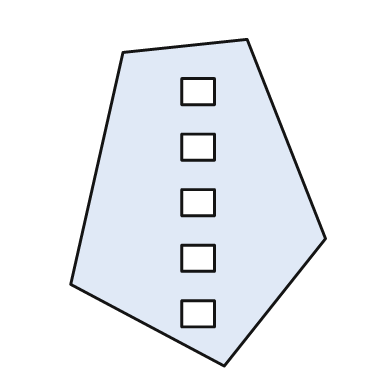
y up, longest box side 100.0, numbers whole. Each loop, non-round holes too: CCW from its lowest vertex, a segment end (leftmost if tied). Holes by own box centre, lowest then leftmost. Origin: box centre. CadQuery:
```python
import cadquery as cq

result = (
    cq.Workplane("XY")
    .moveTo(8.0, -50.0)
    .lineTo(39.0, -11.0)
    .lineTo(15.0, 50.0)
    .lineTo(-23.0, 46.0)
    .lineTo(-39.0, -25.0)
    .close()
    .moveTo(-5.0, -38.0)
    .lineTo(5.0, -38.0)
    .lineTo(5.0, -30.0)
    .lineTo(-5.0, -30.0)
    .close()
    .moveTo(-5.0, -21.0)
    .lineTo(5.0, -21.0)
    .lineTo(5.0, -13.0)
    .lineTo(-5.0, -13.0)
    .close()
    .moveTo(-5.0, -4.0)
    .lineTo(5.0, -4.0)
    .lineTo(5.0, 4.0)
    .lineTo(-5.0, 4.0)
    .close()
    .moveTo(-5.0, 13.0)
    .lineTo(5.0, 13.0)
    .lineTo(5.0, 21.0)
    .lineTo(-5.0, 21.0)
    .close()
    .moveTo(-5.0, 30.0)
    .lineTo(5.0, 30.0)
    .lineTo(5.0, 38.0)
    .lineTo(-5.0, 38.0)
    .close()
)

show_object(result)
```